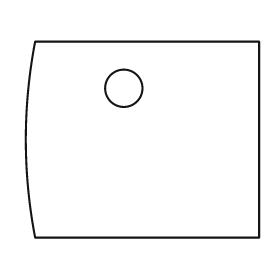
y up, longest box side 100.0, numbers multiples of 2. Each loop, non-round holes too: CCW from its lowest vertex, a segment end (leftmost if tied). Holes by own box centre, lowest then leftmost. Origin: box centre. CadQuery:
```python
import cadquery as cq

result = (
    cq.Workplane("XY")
    .moveTo(-46.0, -42.0)
    .lineTo(50.0, -42.0)
    .lineTo(50.0, 42.0)
    .lineTo(-46.0, 42.0)
    .threePointArc((-50.0, 0.0), (-46.0, -42.0))
    .close()
    .moveTo(-8.0, 22.0)
    .circle(8.0)
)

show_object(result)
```